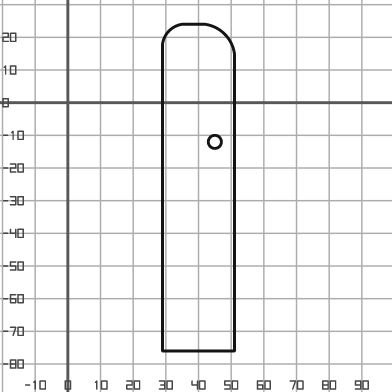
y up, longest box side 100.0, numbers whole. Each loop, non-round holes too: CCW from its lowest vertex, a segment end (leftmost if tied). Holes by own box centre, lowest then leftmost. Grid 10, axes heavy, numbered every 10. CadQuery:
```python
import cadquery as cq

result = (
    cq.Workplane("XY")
    .moveTo(29.0, -76.0)
    .lineTo(51.0, -76.0)
    .lineTo(51.0, 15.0)
    .threePointArc((48.0, 21.0), (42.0, 24.0))
    .lineTo(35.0, 24.0)
    .threePointArc((31.0, 22.0), (29.0, 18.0))
    .close()
    .moveTo(45.0, -12.0)
    .circle(2.0)
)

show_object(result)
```